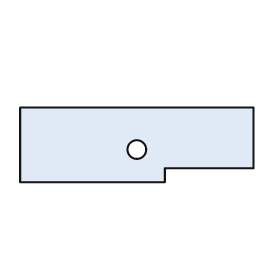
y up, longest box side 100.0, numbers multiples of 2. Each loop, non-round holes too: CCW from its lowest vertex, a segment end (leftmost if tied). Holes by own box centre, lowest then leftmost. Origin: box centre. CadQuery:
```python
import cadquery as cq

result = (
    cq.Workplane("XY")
    .moveTo(-50.0, -16.0)
    .lineTo(12.0, -16.0)
    .lineTo(12.0, -10.0)
    .lineTo(50.0, -10.0)
    .lineTo(50.0, 16.0)
    .lineTo(-50.0, 16.0)
    .close()
    .moveTo(0.0, -2.0)
    .circle(4.0)
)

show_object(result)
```